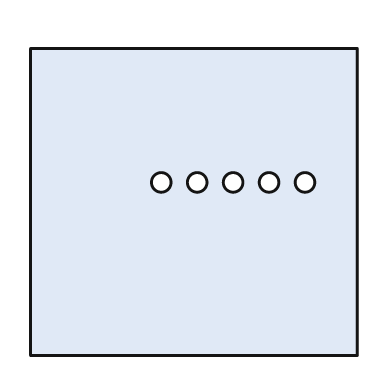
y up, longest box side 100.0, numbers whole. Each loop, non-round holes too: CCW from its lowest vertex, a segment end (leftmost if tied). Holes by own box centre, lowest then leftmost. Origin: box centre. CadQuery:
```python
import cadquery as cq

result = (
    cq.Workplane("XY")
    .moveTo(-50.0, -47.0)
    .lineTo(50.0, -47.0)
    .lineTo(50.0, 47.0)
    .lineTo(-50.0, 47.0)
    .close()
    .moveTo(-10.0, 6.0)
    .circle(3.0)
    .moveTo(1.0, 6.0)
    .circle(3.0)
    .moveTo(12.0, 6.0)
    .circle(3.0)
    .moveTo(23.0, 6.0)
    .circle(3.0)
    .moveTo(34.0, 6.0)
    .circle(3.0)
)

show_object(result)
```